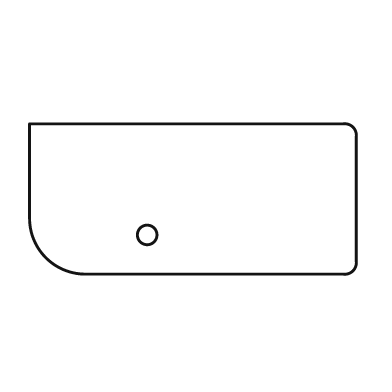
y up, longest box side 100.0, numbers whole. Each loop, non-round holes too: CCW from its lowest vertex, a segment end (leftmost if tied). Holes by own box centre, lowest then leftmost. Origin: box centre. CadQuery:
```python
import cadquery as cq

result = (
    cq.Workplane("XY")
    .moveTo(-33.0, -23.0)
    .lineTo(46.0, -23.0)
    .threePointArc((49.0, -22.0), (50.0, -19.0))
    .lineTo(50.0, 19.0)
    .threePointArc((49.0, 22.0), (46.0, 23.0))
    .lineTo(-50.0, 23.0)
    .lineTo(-50.0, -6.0)
    .threePointArc((-45.0, -18.0), (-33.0, -23.0))
    .close()
    .moveTo(-14.0, -11.0)
    .circle(3.0)
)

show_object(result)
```